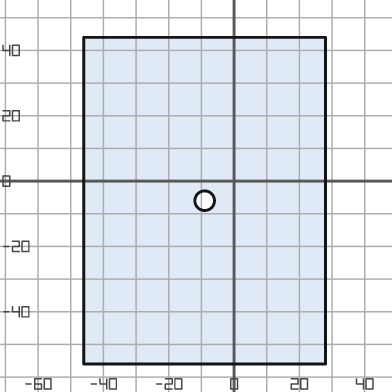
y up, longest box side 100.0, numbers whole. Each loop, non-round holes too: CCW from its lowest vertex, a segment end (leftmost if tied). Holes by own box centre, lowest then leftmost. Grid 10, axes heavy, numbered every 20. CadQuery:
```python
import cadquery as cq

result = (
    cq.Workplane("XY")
    .moveTo(-46.0, -56.0)
    .lineTo(28.0, -56.0)
    .lineTo(28.0, 44.0)
    .lineTo(-46.0, 44.0)
    .close()
    .moveTo(-9.0, -6.0)
    .circle(3.0)
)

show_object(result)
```